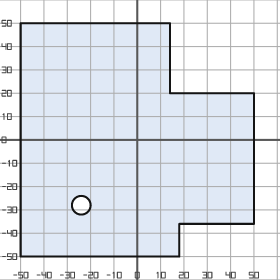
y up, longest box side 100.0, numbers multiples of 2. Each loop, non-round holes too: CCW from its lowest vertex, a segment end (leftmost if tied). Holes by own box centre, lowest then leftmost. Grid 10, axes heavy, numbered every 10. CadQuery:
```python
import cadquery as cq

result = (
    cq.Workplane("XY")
    .moveTo(-50.0, -50.0)
    .lineTo(18.0, -50.0)
    .lineTo(18.0, -36.0)
    .lineTo(50.0, -36.0)
    .lineTo(50.0, 20.0)
    .lineTo(14.0, 20.0)
    .lineTo(14.0, 50.0)
    .lineTo(-50.0, 50.0)
    .close()
    .moveTo(-24.0, -28.0)
    .circle(4.0)
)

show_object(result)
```